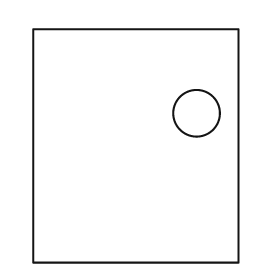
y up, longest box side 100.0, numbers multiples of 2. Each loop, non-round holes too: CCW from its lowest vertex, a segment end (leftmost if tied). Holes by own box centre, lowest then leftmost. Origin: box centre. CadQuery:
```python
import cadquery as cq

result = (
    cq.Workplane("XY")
    .moveTo(-44.0, -50.0)
    .lineTo(44.0, -50.0)
    .lineTo(44.0, 50.0)
    .lineTo(-44.0, 50.0)
    .close()
    .moveTo(26.0, 14.0)
    .circle(10.0)
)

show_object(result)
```